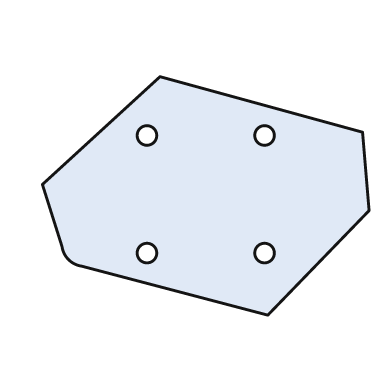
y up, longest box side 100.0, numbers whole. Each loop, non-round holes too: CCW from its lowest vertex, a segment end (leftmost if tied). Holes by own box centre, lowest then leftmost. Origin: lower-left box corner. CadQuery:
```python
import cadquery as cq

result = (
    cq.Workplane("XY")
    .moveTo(69.0, 0.0)
    .lineTo(100.0, 32.0)
    .lineTo(98.0, 56.0)
    .lineTo(36.0, 73.0)
    .lineTo(0.0, 40.0)
    .lineTo(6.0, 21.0)
    .threePointArc((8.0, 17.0), (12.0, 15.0))
    .close()
    .moveTo(32.0, 19.0)
    .circle(3.0)
    .moveTo(68.0, 19.0)
    .circle(3.0)
    .moveTo(32.0, 55.0)
    .circle(3.0)
    .moveTo(68.0, 55.0)
    .circle(3.0)
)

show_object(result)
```